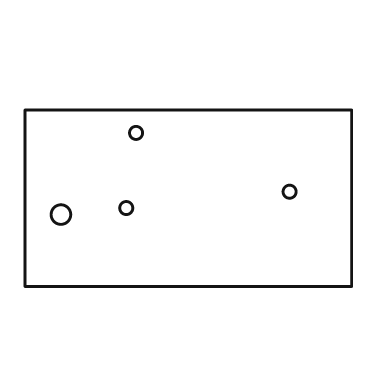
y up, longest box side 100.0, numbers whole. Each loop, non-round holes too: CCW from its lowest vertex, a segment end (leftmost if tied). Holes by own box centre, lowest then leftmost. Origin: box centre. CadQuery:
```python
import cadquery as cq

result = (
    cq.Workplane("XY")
    .moveTo(-50.0, -27.0)
    .lineTo(50.0, -27.0)
    .lineTo(50.0, 27.0)
    .lineTo(-50.0, 27.0)
    .close()
    .moveTo(-39.0, -5.0)
    .circle(3.0)
    .moveTo(-19.0, -3.0)
    .circle(2.0)
    .moveTo(31.0, 2.0)
    .circle(2.0)
    .moveTo(-16.0, 20.0)
    .circle(2.0)
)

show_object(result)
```